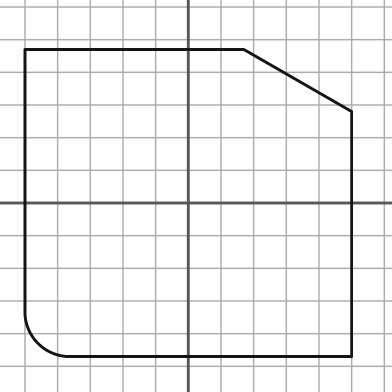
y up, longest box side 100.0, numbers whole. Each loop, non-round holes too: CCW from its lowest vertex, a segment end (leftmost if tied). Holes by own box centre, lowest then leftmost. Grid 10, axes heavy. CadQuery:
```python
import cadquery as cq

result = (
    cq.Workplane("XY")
    .moveTo(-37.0, -47.0)
    .lineTo(50.0, -47.0)
    .lineTo(50.0, 28.0)
    .lineTo(17.0, 47.0)
    .lineTo(-50.0, 47.0)
    .lineTo(-50.0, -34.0)
    .threePointArc((-46.0, -43.0), (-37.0, -47.0))
    .close()
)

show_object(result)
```